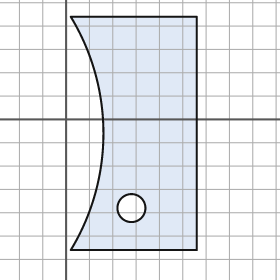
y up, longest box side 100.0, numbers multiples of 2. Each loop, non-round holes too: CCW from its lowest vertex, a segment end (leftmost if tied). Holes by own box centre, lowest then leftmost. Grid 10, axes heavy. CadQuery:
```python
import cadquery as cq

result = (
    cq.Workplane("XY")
    .moveTo(2.0, -56.0)
    .lineTo(56.0, -56.0)
    .lineTo(56.0, 44.0)
    .lineTo(2.0, 44.0)
    .threePointArc((16.0, -6.0), (2.0, -56.0))
    .close()
    .moveTo(28.0, -38.0)
    .circle(6.0)
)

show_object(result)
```